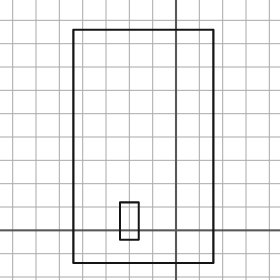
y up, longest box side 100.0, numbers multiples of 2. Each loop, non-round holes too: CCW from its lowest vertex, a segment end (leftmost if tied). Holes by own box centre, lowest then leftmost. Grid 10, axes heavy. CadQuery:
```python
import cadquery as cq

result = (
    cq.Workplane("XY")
    .moveTo(-44.0, -14.0)
    .lineTo(16.0, -14.0)
    .lineTo(16.0, 86.0)
    .lineTo(-44.0, 86.0)
    .close()
    .moveTo(-24.0, -4.0)
    .lineTo(-16.0, -4.0)
    .lineTo(-16.0, 12.0)
    .lineTo(-24.0, 12.0)
    .close()
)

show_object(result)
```